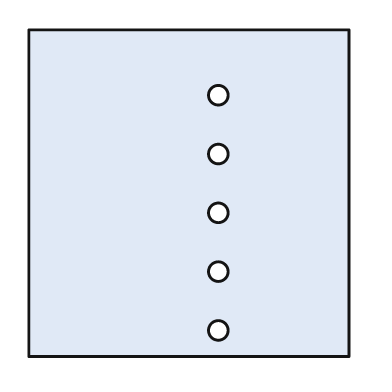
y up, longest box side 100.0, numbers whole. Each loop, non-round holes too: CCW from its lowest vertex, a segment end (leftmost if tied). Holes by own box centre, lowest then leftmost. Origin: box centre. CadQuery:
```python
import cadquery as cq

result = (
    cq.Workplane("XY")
    .moveTo(-49.0, -50.0)
    .lineTo(49.0, -50.0)
    .lineTo(49.0, 50.0)
    .lineTo(-49.0, 50.0)
    .close()
    .moveTo(9.0, -42.0)
    .circle(3.0)
    .moveTo(9.0, -24.0)
    .circle(3.0)
    .moveTo(9.0, -6.0)
    .circle(3.0)
    .moveTo(9.0, 12.0)
    .circle(3.0)
    .moveTo(9.0, 30.0)
    .circle(3.0)
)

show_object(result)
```